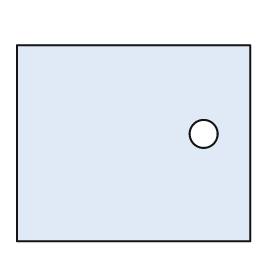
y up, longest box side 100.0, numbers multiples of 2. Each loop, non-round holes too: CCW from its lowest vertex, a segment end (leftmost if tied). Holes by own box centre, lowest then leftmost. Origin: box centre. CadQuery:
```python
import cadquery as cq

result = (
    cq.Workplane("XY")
    .moveTo(-50.0, -42.0)
    .lineTo(50.0, -42.0)
    .lineTo(50.0, 42.0)
    .lineTo(-50.0, 42.0)
    .close()
    .moveTo(30.0, 4.0)
    .circle(6.0)
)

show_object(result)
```